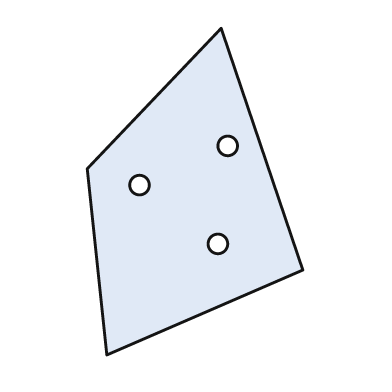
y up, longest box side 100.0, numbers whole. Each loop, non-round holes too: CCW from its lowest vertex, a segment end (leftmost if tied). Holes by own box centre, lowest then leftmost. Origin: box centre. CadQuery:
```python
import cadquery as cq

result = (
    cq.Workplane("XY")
    .moveTo(-27.0, -50.0)
    .lineTo(33.0, -24.0)
    .lineTo(8.0, 50.0)
    .lineTo(-33.0, 7.0)
    .close()
    .moveTo(7.0, -16.0)
    .circle(3.0)
    .moveTo(-17.0, 2.0)
    .circle(3.0)
    .moveTo(10.0, 14.0)
    .circle(3.0)
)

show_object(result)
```